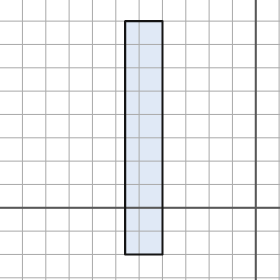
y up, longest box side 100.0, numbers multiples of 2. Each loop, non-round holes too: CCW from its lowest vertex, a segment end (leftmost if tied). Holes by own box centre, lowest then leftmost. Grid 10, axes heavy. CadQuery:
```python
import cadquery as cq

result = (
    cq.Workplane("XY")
    .moveTo(-56.0, -20.0)
    .lineTo(-40.0, -20.0)
    .lineTo(-40.0, 80.0)
    .lineTo(-56.0, 80.0)
    .close()
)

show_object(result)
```